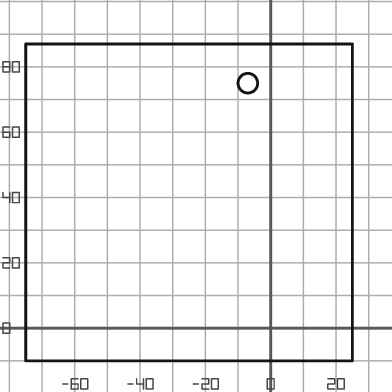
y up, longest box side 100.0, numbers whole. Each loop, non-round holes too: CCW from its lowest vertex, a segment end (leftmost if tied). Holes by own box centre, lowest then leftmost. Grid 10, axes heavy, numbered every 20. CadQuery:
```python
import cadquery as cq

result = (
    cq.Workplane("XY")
    .moveTo(-75.0, -10.0)
    .lineTo(25.0, -10.0)
    .lineTo(25.0, 87.0)
    .lineTo(-75.0, 87.0)
    .close()
    .moveTo(-7.0, 75.0)
    .circle(3.0)
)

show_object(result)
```